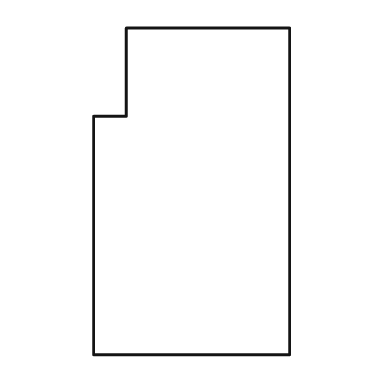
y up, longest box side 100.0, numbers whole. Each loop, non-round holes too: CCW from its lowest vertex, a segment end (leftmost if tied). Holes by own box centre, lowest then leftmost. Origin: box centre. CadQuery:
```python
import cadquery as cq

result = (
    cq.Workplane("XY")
    .moveTo(-30.0, -50.0)
    .lineTo(30.0, -50.0)
    .lineTo(30.0, 50.0)
    .lineTo(-20.0, 50.0)
    .lineTo(-20.0, 23.0)
    .lineTo(-30.0, 23.0)
    .close()
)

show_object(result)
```